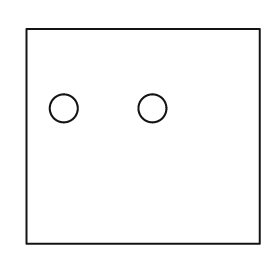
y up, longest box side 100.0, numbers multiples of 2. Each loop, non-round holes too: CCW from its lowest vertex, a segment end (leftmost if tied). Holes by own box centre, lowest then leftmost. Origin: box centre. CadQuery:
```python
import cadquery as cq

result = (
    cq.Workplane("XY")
    .moveTo(-50.0, -46.0)
    .lineTo(50.0, -46.0)
    .lineTo(50.0, 46.0)
    .lineTo(-50.0, 46.0)
    .close()
    .moveTo(-34.0, 12.0)
    .circle(6.0)
    .moveTo(4.0, 12.0)
    .circle(6.0)
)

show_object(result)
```